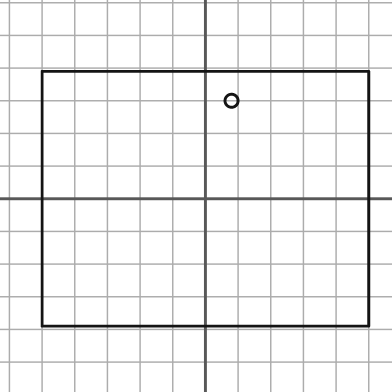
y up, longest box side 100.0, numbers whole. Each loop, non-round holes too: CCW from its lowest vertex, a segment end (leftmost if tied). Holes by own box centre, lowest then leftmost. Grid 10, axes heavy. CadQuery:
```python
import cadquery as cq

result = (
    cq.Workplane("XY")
    .moveTo(-50.0, -39.0)
    .lineTo(50.0, -39.0)
    .lineTo(50.0, 39.0)
    .lineTo(-50.0, 39.0)
    .close()
    .moveTo(8.0, 30.0)
    .circle(2.0)
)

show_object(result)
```